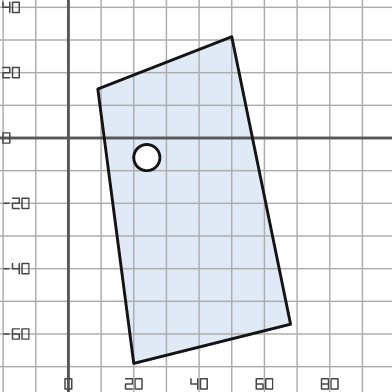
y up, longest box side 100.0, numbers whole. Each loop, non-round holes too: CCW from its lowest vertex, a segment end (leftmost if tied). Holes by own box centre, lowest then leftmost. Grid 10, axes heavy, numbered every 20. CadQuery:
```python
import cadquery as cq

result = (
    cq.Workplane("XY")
    .moveTo(20.0, -69.0)
    .lineTo(68.0, -57.0)
    .lineTo(50.0, 31.0)
    .lineTo(9.0, 15.0)
    .close()
    .moveTo(24.0, -6.0)
    .circle(4.0)
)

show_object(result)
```